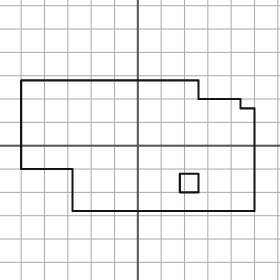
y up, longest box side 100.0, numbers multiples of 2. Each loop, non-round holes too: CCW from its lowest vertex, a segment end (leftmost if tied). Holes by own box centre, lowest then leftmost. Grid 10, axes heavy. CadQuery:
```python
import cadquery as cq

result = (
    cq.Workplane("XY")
    .moveTo(-28.0, -28.0)
    .lineTo(50.0, -28.0)
    .lineTo(50.0, 16.0)
    .lineTo(44.0, 16.0)
    .lineTo(44.0, 20.0)
    .lineTo(26.0, 20.0)
    .lineTo(26.0, 28.0)
    .lineTo(-50.0, 28.0)
    .lineTo(-50.0, -10.0)
    .lineTo(-28.0, -10.0)
    .close()
    .moveTo(18.0, -20.0)
    .lineTo(26.0, -20.0)
    .lineTo(26.0, -12.0)
    .lineTo(18.0, -12.0)
    .close()
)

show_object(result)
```